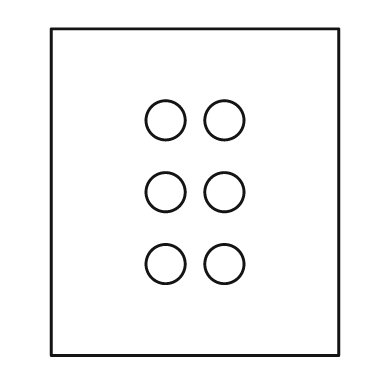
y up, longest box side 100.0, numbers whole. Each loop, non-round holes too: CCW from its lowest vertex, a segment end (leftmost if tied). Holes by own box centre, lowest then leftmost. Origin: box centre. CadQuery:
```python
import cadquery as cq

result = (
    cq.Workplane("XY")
    .moveTo(-44.0, -50.0)
    .lineTo(44.0, -50.0)
    .lineTo(44.0, 50.0)
    .lineTo(-44.0, 50.0)
    .close()
    .moveTo(-9.0, -22.0)
    .circle(6.0)
    .moveTo(9.0, -22.0)
    .circle(6.0)
    .moveTo(-9.0, 0.0)
    .circle(6.0)
    .moveTo(9.0, 0.0)
    .circle(6.0)
    .moveTo(-9.0, 22.0)
    .circle(6.0)
    .moveTo(9.0, 22.0)
    .circle(6.0)
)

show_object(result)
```